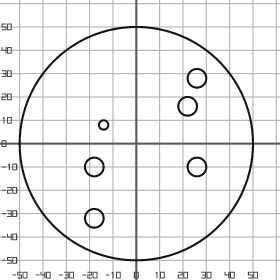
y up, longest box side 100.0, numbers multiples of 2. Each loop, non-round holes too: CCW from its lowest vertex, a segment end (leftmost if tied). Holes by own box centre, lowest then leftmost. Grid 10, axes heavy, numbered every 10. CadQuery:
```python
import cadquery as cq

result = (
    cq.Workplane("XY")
    .moveTo(0.0, 0.0)
    .circle(50.0)
    .moveTo(-18.0, -32.0)
    .circle(4.0)
    .moveTo(-18.0, -10.0)
    .circle(4.0)
    .moveTo(26.0, -10.0)
    .circle(4.0)
    .moveTo(-14.0, 8.0)
    .circle(2.0)
    .moveTo(22.0, 16.0)
    .circle(4.0)
    .moveTo(26.0, 28.0)
    .circle(4.0)
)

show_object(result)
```